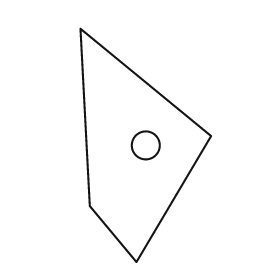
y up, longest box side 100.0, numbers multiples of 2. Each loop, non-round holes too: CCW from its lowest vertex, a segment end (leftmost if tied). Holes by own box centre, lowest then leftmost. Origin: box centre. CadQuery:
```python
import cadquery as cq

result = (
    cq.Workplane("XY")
    .moveTo(-4.0, -50.0)
    .lineTo(28.0, 4.0)
    .lineTo(-28.0, 50.0)
    .lineTo(-24.0, -26.0)
    .close()
    .moveTo(0.0, 0.0)
    .circle(6.0)
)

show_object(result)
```